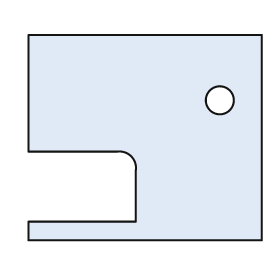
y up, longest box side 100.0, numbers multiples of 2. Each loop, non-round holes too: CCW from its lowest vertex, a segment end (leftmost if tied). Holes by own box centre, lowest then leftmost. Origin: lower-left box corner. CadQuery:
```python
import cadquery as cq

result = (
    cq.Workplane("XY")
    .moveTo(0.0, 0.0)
    .lineTo(100.0, 0.0)
    .lineTo(100.0, 88.0)
    .lineTo(0.0, 88.0)
    .lineTo(0.0, 38.0)
    .lineTo(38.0, 38.0)
    .threePointArc((44.0, 36.0), (46.0, 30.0))
    .lineTo(46.0, 8.0)
    .lineTo(0.0, 8.0)
    .close()
    .moveTo(82.0, 60.0)
    .circle(6.0)
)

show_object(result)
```